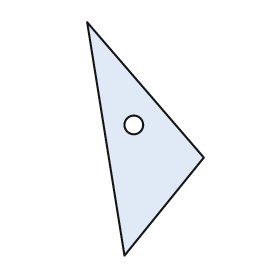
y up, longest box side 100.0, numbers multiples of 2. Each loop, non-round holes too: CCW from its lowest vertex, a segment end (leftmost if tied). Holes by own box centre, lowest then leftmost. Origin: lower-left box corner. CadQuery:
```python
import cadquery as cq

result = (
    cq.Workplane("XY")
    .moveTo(16.0, 0.0)
    .lineTo(50.0, 42.0)
    .lineTo(0.0, 100.0)
    .close()
    .moveTo(20.0, 56.0)
    .circle(4.0)
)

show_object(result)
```